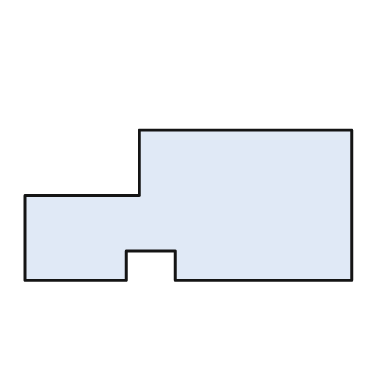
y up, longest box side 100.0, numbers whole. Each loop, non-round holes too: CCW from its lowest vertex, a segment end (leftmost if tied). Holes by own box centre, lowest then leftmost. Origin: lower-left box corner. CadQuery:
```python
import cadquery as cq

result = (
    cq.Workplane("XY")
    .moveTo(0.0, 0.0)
    .lineTo(31.0, 0.0)
    .lineTo(31.0, 9.0)
    .lineTo(46.0, 9.0)
    .lineTo(46.0, 0.0)
    .lineTo(100.0, 0.0)
    .lineTo(100.0, 46.0)
    .lineTo(35.0, 46.0)
    .lineTo(35.0, 26.0)
    .lineTo(0.0, 26.0)
    .close()
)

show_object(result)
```